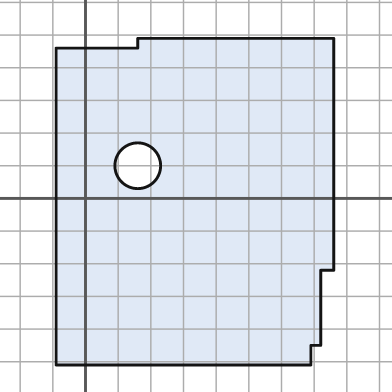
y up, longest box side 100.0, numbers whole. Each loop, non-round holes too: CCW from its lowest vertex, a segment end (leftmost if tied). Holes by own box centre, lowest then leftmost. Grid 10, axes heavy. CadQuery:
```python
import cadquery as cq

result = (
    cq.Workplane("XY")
    .moveTo(-9.0, -51.0)
    .lineTo(69.0, -51.0)
    .lineTo(69.0, -45.0)
    .lineTo(72.0, -45.0)
    .lineTo(72.0, -22.0)
    .lineTo(76.0, -22.0)
    .lineTo(76.0, 49.0)
    .lineTo(16.0, 49.0)
    .lineTo(16.0, 46.0)
    .lineTo(-9.0, 46.0)
    .close()
    .moveTo(16.0, 10.0)
    .circle(7.0)
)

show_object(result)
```